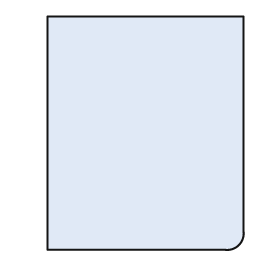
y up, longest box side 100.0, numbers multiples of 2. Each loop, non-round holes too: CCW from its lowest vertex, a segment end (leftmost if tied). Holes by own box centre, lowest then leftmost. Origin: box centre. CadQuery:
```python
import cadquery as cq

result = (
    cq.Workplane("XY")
    .moveTo(-42.0, -50.0)
    .lineTo(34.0, -50.0)
    .threePointArc((40.0, -48.0), (42.0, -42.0))
    .lineTo(42.0, 50.0)
    .lineTo(-42.0, 50.0)
    .close()
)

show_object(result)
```